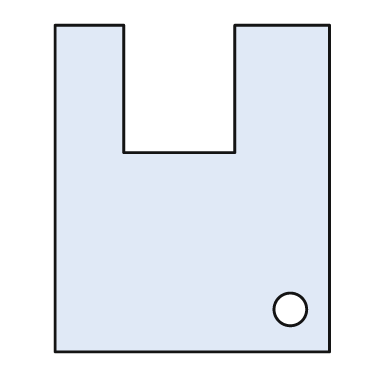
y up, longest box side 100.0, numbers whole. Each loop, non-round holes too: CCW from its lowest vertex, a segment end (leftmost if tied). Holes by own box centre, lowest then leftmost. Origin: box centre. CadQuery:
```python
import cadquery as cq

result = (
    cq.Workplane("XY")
    .moveTo(-42.0, -50.0)
    .lineTo(42.0, -50.0)
    .lineTo(42.0, 50.0)
    .lineTo(13.0, 50.0)
    .lineTo(13.0, 11.0)
    .lineTo(-21.0, 11.0)
    .lineTo(-21.0, 50.0)
    .lineTo(-42.0, 50.0)
    .close()
    .moveTo(30.0, -37.0)
    .circle(5.0)
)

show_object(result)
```